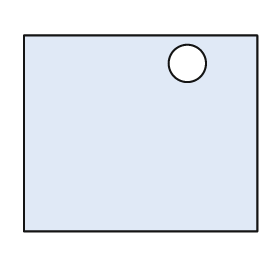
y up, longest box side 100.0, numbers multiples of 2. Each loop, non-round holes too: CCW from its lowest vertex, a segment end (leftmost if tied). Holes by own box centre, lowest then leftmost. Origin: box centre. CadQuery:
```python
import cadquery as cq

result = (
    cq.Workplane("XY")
    .moveTo(-50.0, -42.0)
    .lineTo(50.0, -42.0)
    .lineTo(50.0, 42.0)
    .lineTo(-50.0, 42.0)
    .close()
    .moveTo(20.0, 30.0)
    .circle(8.0)
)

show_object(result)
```